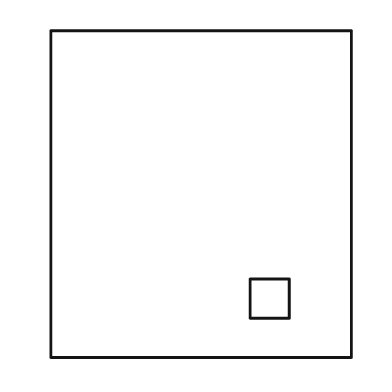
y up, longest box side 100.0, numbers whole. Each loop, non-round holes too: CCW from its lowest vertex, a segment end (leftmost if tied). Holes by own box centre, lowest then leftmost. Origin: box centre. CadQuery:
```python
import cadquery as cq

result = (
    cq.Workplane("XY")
    .moveTo(-46.0, -50.0)
    .lineTo(46.0, -50.0)
    .lineTo(46.0, 50.0)
    .lineTo(-46.0, 50.0)
    .close()
    .moveTo(15.0, -38.0)
    .lineTo(27.0, -38.0)
    .lineTo(27.0, -26.0)
    .lineTo(15.0, -26.0)
    .close()
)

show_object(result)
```